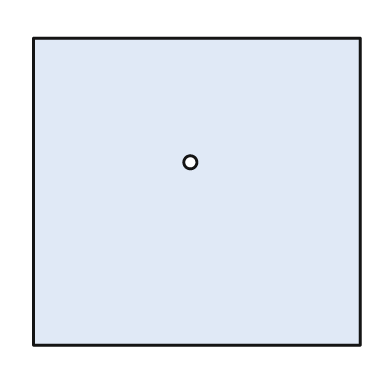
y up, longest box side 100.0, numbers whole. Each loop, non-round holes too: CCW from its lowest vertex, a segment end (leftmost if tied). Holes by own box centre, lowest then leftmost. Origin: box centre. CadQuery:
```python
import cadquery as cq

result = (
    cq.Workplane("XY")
    .moveTo(-50.0, -47.0)
    .lineTo(50.0, -47.0)
    .lineTo(50.0, 47.0)
    .lineTo(-50.0, 47.0)
    .close()
    .moveTo(-2.0, 9.0)
    .circle(2.0)
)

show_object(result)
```